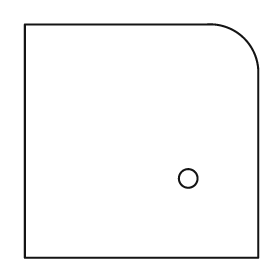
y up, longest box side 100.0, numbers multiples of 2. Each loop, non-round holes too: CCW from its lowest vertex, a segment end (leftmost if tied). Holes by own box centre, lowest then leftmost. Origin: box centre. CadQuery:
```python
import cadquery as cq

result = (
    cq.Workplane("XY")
    .moveTo(-50.0, -50.0)
    .lineTo(50.0, -50.0)
    .lineTo(50.0, 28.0)
    .threePointArc((44.0, 44.0), (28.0, 50.0))
    .lineTo(-50.0, 50.0)
    .close()
    .moveTo(20.0, -16.0)
    .circle(4.0)
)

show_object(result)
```